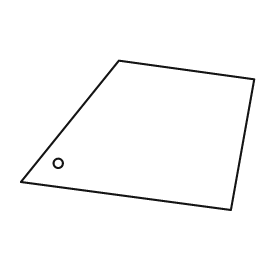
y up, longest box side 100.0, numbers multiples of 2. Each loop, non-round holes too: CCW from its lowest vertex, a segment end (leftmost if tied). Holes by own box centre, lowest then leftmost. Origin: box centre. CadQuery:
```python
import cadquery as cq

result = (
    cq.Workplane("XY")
    .moveTo(40.0, -32.0)
    .lineTo(50.0, 24.0)
    .lineTo(-8.0, 32.0)
    .lineTo(-50.0, -20.0)
    .close()
    .moveTo(-34.0, -12.0)
    .circle(2.0)
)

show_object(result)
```